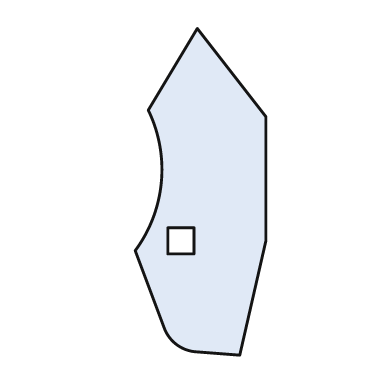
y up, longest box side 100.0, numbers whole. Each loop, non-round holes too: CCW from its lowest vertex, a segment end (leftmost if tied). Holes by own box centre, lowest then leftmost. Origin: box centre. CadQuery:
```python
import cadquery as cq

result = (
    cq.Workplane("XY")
    .moveTo(12.0, -50.0)
    .lineTo(20.0, -15.0)
    .lineTo(20.0, 23.0)
    .lineTo(-1.0, 50.0)
    .lineTo(-16.0, 25.0)
    .threePointArc((-12.0, 3.0), (-20.0, -18.0))
    .lineTo(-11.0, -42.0)
    .threePointArc((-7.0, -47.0), (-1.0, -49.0))
    .close()
    .moveTo(-10.0, -19.0)
    .lineTo(-2.0, -19.0)
    .lineTo(-2.0, -11.0)
    .lineTo(-10.0, -11.0)
    .close()
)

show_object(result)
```